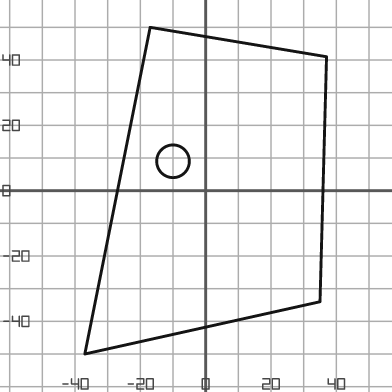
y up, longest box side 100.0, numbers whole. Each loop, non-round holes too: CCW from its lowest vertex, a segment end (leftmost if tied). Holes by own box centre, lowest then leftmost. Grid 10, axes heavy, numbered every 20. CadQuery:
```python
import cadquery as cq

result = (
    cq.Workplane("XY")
    .moveTo(-37.0, -50.0)
    .lineTo(35.0, -34.0)
    .lineTo(37.0, 41.0)
    .lineTo(-17.0, 50.0)
    .close()
    .moveTo(-10.0, 9.0)
    .circle(5.0)
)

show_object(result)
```